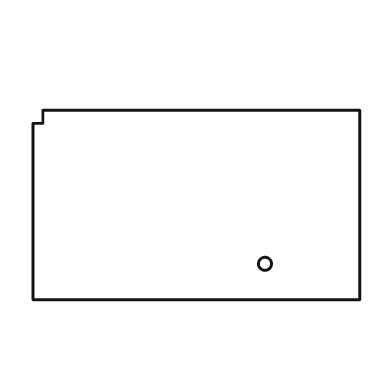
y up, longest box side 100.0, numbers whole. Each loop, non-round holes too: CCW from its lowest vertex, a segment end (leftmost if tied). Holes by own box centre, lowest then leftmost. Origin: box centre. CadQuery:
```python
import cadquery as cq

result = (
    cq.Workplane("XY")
    .moveTo(-50.0, -29.0)
    .lineTo(50.0, -29.0)
    .lineTo(50.0, 29.0)
    .lineTo(-47.0, 29.0)
    .lineTo(-47.0, 25.0)
    .lineTo(-50.0, 25.0)
    .close()
    .moveTo(21.0, -18.0)
    .circle(2.0)
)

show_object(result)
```